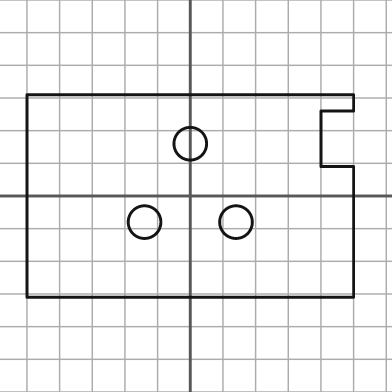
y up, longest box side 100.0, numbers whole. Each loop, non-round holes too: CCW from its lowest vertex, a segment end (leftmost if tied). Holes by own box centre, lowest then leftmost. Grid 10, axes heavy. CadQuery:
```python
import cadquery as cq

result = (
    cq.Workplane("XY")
    .moveTo(-50.0, -31.0)
    .lineTo(50.0, -31.0)
    .lineTo(50.0, 9.0)
    .lineTo(40.0, 9.0)
    .lineTo(40.0, 26.0)
    .lineTo(50.0, 26.0)
    .lineTo(50.0, 31.0)
    .lineTo(-50.0, 31.0)
    .close()
    .moveTo(-14.0, -8.0)
    .circle(5.0)
    .moveTo(14.0, -8.0)
    .circle(5.0)
    .moveTo(0.0, 16.0)
    .circle(5.0)
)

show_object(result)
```